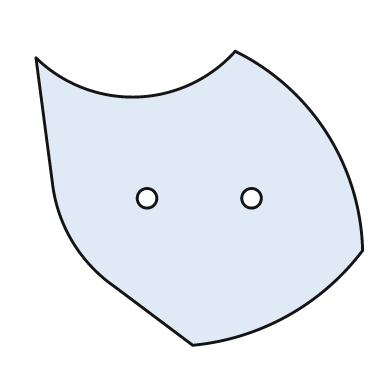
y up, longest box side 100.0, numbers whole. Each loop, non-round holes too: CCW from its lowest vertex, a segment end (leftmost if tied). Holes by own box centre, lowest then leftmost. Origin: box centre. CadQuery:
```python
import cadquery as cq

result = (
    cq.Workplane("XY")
    .moveTo(-2.0, -45.0)
    .threePointArc((27.0, -36.0), (50.0, -16.0))
    .threePointArc((39.0, 20.0), (11.0, 45.0))
    .threePointArc((-19.0, 31.0), (-50.0, 43.0))
    .lineTo(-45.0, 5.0)
    .threePointArc((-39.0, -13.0), (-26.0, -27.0))
    .close()
    .moveTo(-16.0, 0.0)
    .circle(3.0)
    .moveTo(16.0, 0.0)
    .circle(3.0)
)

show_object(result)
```